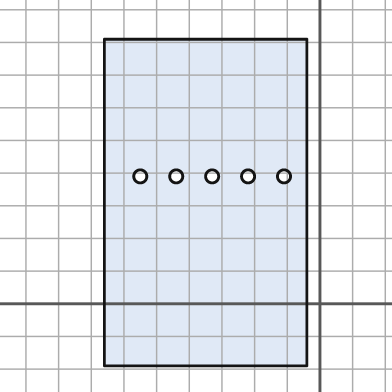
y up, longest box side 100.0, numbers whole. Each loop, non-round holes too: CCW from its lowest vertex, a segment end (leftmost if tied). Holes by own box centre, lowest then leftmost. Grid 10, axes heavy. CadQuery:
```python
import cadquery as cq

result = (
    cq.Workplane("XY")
    .moveTo(-66.0, -19.0)
    .lineTo(-4.0, -19.0)
    .lineTo(-4.0, 81.0)
    .lineTo(-66.0, 81.0)
    .close()
    .moveTo(-55.0, 39.0)
    .circle(2.0)
    .moveTo(-44.0, 39.0)
    .circle(2.0)
    .moveTo(-33.0, 39.0)
    .circle(2.0)
    .moveTo(-22.0, 39.0)
    .circle(2.0)
    .moveTo(-11.0, 39.0)
    .circle(2.0)
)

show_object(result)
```